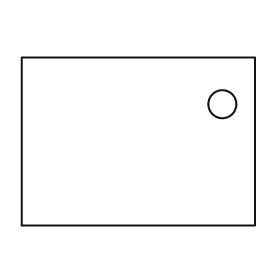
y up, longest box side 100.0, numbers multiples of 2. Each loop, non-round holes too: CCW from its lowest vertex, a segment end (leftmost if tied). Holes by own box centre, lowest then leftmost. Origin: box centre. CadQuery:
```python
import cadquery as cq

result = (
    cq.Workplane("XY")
    .moveTo(-50.0, -36.0)
    .lineTo(50.0, -36.0)
    .lineTo(50.0, 36.0)
    .lineTo(-50.0, 36.0)
    .close()
    .moveTo(36.0, 16.0)
    .circle(6.0)
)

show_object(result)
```